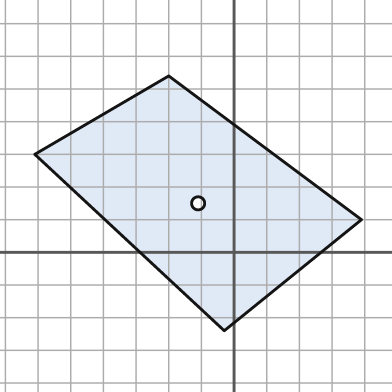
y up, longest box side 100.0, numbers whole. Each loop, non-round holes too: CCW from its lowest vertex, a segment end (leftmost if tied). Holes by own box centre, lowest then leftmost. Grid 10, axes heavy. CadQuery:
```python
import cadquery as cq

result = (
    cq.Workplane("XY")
    .moveTo(-3.0, -24.0)
    .lineTo(39.0, 10.0)
    .lineTo(-20.0, 54.0)
    .lineTo(-61.0, 30.0)
    .close()
    .moveTo(-11.0, 15.0)
    .circle(2.0)
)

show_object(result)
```